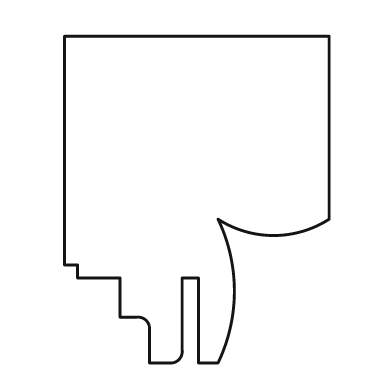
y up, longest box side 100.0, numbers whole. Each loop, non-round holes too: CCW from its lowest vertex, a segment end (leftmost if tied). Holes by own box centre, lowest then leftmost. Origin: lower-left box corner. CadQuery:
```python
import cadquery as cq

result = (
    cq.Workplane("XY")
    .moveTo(26.0, 0.0)
    .lineTo(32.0, 0.0)
    .threePointArc((35.0, 1.0), (36.0, 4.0))
    .lineTo(36.0, 26.0)
    .lineTo(41.0, 26.0)
    .lineTo(41.0, 0.0)
    .lineTo(47.0, 0.0)
    .threePointArc((52.0, 22.0), (47.0, 44.0))
    .threePointArc((64.0, 39.0), (81.0, 44.0))
    .lineTo(81.0, 100.0)
    .lineTo(0.0, 100.0)
    .lineTo(0.0, 30.0)
    .lineTo(4.0, 30.0)
    .lineTo(4.0, 26.0)
    .lineTo(17.0, 26.0)
    .lineTo(17.0, 14.0)
    .lineTo(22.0, 14.0)
    .threePointArc((25.0, 13.0), (26.0, 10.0))
    .close()
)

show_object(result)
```